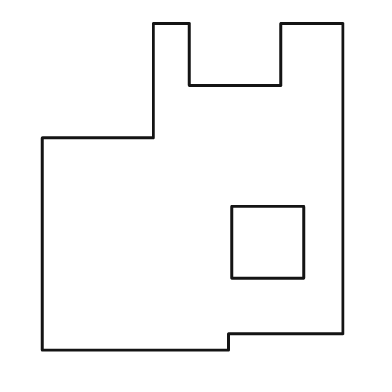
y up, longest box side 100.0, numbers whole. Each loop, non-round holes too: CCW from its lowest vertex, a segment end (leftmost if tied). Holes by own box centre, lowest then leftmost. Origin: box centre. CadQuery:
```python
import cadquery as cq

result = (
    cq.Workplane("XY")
    .moveTo(-46.0, -50.0)
    .lineTo(11.0, -50.0)
    .lineTo(11.0, -45.0)
    .lineTo(46.0, -45.0)
    .lineTo(46.0, 50.0)
    .lineTo(27.0, 50.0)
    .lineTo(27.0, 31.0)
    .lineTo(-1.0, 31.0)
    .lineTo(-1.0, 50.0)
    .lineTo(-12.0, 50.0)
    .lineTo(-12.0, 15.0)
    .lineTo(-46.0, 15.0)
    .close()
    .moveTo(12.0, -28.0)
    .lineTo(34.0, -28.0)
    .lineTo(34.0, -6.0)
    .lineTo(12.0, -6.0)
    .close()
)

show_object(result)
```